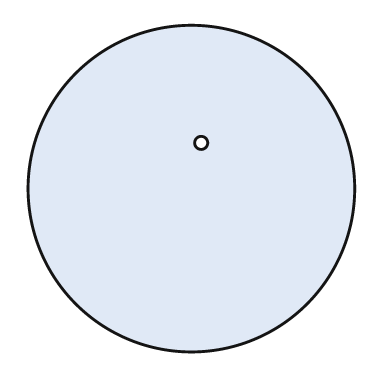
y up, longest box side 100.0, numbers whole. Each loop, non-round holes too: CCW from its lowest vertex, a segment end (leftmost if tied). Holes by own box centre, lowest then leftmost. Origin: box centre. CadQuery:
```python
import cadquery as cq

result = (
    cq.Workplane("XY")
    .moveTo(0.0, 0.0)
    .circle(50.0)
    .moveTo(3.0, 14.0)
    .circle(2.0)
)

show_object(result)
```